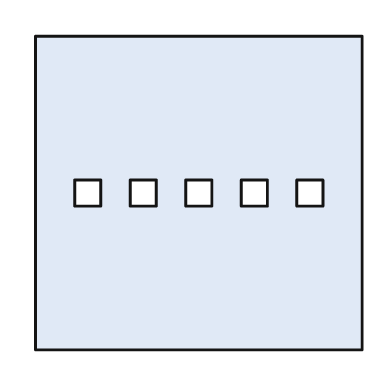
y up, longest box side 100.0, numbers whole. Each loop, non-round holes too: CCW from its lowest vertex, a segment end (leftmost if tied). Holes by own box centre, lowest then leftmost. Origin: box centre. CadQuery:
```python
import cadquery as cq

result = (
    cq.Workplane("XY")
    .moveTo(-50.0, -48.0)
    .lineTo(50.0, -48.0)
    .lineTo(50.0, 48.0)
    .lineTo(-50.0, 48.0)
    .close()
    .moveTo(-38.0, -4.0)
    .lineTo(-30.0, -4.0)
    .lineTo(-30.0, 4.0)
    .lineTo(-38.0, 4.0)
    .close()
    .moveTo(-21.0, -4.0)
    .lineTo(-13.0, -4.0)
    .lineTo(-13.0, 4.0)
    .lineTo(-21.0, 4.0)
    .close()
    .moveTo(-4.0, -4.0)
    .lineTo(4.0, -4.0)
    .lineTo(4.0, 4.0)
    .lineTo(-4.0, 4.0)
    .close()
    .moveTo(13.0, -4.0)
    .lineTo(21.0, -4.0)
    .lineTo(21.0, 4.0)
    .lineTo(13.0, 4.0)
    .close()
    .moveTo(30.0, -4.0)
    .lineTo(38.0, -4.0)
    .lineTo(38.0, 4.0)
    .lineTo(30.0, 4.0)
    .close()
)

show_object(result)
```